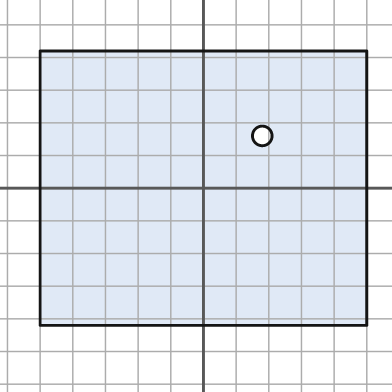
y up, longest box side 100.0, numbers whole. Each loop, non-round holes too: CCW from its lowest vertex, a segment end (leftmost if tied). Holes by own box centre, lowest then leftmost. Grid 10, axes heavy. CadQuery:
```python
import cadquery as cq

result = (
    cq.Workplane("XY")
    .moveTo(-50.0, -42.0)
    .lineTo(50.0, -42.0)
    .lineTo(50.0, 42.0)
    .lineTo(-50.0, 42.0)
    .close()
    .moveTo(18.0, 16.0)
    .circle(3.0)
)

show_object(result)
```